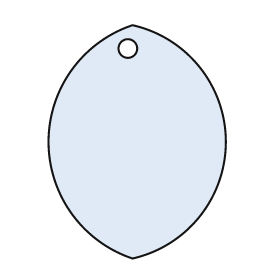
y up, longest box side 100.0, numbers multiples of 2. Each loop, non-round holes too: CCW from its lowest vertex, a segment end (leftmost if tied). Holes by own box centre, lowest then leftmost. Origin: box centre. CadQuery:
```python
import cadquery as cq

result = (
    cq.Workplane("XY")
    .moveTo(-2.0, -50.0)
    .threePointArc((38.0, 0.0), (-2.0, 50.0))
    .threePointArc((-38.0, 0.0), (-2.0, -50.0))
    .close()
    .moveTo(-4.0, 40.0)
    .circle(4.0)
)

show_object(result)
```